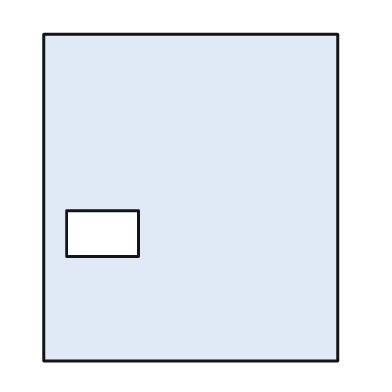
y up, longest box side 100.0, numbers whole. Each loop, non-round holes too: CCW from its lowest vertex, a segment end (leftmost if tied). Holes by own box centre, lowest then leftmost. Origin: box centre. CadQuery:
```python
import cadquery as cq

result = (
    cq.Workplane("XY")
    .moveTo(-45.0, -50.0)
    .lineTo(45.0, -50.0)
    .lineTo(45.0, 50.0)
    .lineTo(-45.0, 50.0)
    .close()
    .moveTo(-38.0, -18.0)
    .lineTo(-16.0, -18.0)
    .lineTo(-16.0, -4.0)
    .lineTo(-38.0, -4.0)
    .close()
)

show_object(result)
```